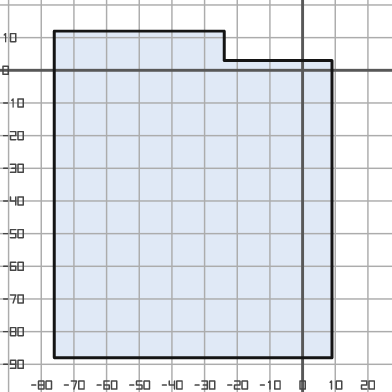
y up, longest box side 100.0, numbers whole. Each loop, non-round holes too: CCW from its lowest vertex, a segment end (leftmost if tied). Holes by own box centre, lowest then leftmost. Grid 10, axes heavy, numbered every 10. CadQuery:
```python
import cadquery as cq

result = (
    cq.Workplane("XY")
    .moveTo(-76.0, -88.0)
    .lineTo(9.0, -88.0)
    .lineTo(9.0, 3.0)
    .lineTo(-24.0, 3.0)
    .lineTo(-24.0, 12.0)
    .lineTo(-76.0, 12.0)
    .close()
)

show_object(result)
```